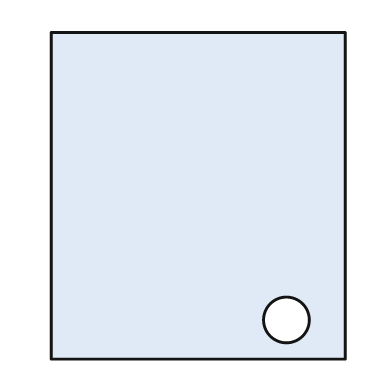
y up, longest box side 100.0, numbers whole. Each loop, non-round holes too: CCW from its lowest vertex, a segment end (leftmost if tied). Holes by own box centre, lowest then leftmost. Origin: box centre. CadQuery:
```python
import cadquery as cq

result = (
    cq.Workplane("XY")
    .moveTo(-45.0, -50.0)
    .lineTo(45.0, -50.0)
    .lineTo(45.0, 50.0)
    .lineTo(-45.0, 50.0)
    .close()
    .moveTo(27.0, -38.0)
    .circle(7.0)
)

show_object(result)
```